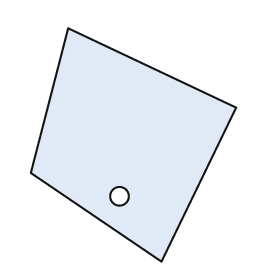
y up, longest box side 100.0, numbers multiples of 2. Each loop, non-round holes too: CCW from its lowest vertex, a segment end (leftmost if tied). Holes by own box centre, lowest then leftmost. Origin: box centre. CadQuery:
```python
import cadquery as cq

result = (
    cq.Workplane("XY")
    .moveTo(12.0, -50.0)
    .lineTo(44.0, 16.0)
    .lineTo(-28.0, 50.0)
    .lineTo(-44.0, -12.0)
    .close()
    .moveTo(-6.0, -22.0)
    .circle(4.0)
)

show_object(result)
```